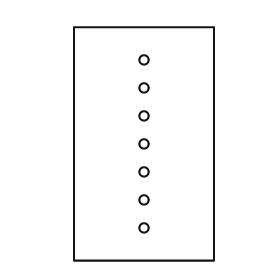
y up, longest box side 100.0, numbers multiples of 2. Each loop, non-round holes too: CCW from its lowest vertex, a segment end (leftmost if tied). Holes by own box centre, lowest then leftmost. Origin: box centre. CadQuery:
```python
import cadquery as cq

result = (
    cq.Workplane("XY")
    .moveTo(-30.0, -50.0)
    .lineTo(30.0, -50.0)
    .lineTo(30.0, 50.0)
    .lineTo(-30.0, 50.0)
    .close()
    .moveTo(0.0, -36.0)
    .circle(2.0)
    .moveTo(0.0, -24.0)
    .circle(2.0)
    .moveTo(0.0, -12.0)
    .circle(2.0)
    .moveTo(0.0, 0.0)
    .circle(2.0)
    .moveTo(0.0, 12.0)
    .circle(2.0)
    .moveTo(0.0, 24.0)
    .circle(2.0)
    .moveTo(0.0, 36.0)
    .circle(2.0)
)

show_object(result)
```